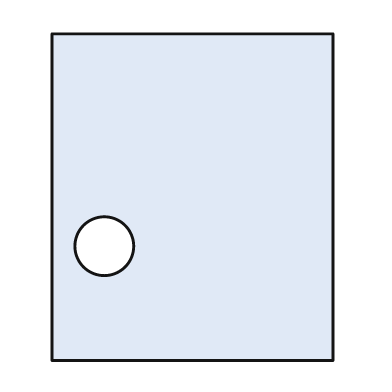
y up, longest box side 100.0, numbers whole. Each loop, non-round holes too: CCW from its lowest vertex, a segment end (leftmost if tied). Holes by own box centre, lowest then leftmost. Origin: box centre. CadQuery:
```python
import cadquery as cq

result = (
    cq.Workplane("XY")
    .moveTo(-43.0, -50.0)
    .lineTo(43.0, -50.0)
    .lineTo(43.0, 50.0)
    .lineTo(-43.0, 50.0)
    .close()
    .moveTo(-27.0, -15.0)
    .circle(9.0)
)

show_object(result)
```